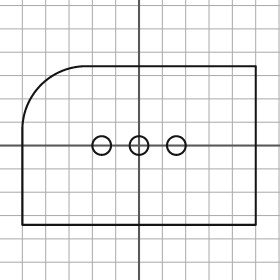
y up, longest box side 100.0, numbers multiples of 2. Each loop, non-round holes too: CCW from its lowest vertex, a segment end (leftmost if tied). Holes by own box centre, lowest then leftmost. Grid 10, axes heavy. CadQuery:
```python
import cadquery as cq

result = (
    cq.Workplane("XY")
    .moveTo(-50.0, -34.0)
    .lineTo(50.0, -34.0)
    .lineTo(50.0, 34.0)
    .lineTo(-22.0, 34.0)
    .threePointArc((-42.0, 26.0), (-50.0, 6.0))
    .close()
    .moveTo(-16.0, 0.0)
    .circle(4.0)
    .moveTo(0.0, 0.0)
    .circle(4.0)
    .moveTo(16.0, 0.0)
    .circle(4.0)
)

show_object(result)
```